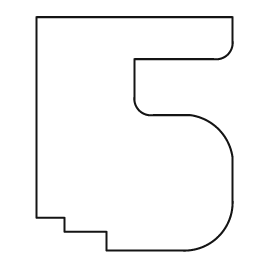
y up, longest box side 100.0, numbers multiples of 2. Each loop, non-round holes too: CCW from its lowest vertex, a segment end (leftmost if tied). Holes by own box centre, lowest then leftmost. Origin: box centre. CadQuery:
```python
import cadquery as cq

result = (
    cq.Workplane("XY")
    .moveTo(-12.0, -50.0)
    .lineTo(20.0, -50.0)
    .threePointArc((36.0, -44.0), (42.0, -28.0))
    .lineTo(42.0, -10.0)
    .threePointArc((36.0, 2.0), (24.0, 8.0))
    .lineTo(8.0, 8.0)
    .threePointArc((2.0, 10.0), (0.0, 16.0))
    .lineTo(0.0, 32.0)
    .lineTo(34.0, 32.0)
    .threePointArc((40.0, 34.0), (42.0, 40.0))
    .lineTo(42.0, 50.0)
    .lineTo(-42.0, 50.0)
    .lineTo(-42.0, -36.0)
    .lineTo(-30.0, -36.0)
    .lineTo(-30.0, -42.0)
    .lineTo(-12.0, -42.0)
    .close()
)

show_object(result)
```